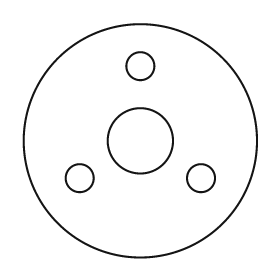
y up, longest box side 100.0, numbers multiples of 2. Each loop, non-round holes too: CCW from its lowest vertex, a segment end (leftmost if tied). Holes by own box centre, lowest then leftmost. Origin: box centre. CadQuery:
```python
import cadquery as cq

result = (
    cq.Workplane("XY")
    .moveTo(0.0, 0.0)
    .circle(50.0)
    .moveTo(-26.0, -16.0)
    .circle(6.0)
    .moveTo(26.0, -16.0)
    .circle(6.0)
    .moveTo(0.0, 0.0)
    .circle(14.0)
    .moveTo(0.0, 32.0)
    .circle(6.0)
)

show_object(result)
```